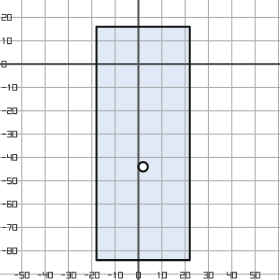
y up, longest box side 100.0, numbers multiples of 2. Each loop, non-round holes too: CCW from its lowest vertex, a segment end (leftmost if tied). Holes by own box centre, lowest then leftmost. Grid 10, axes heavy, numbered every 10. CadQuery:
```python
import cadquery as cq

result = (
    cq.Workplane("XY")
    .moveTo(-18.0, -84.0)
    .lineTo(22.0, -84.0)
    .lineTo(22.0, 16.0)
    .lineTo(-18.0, 16.0)
    .close()
    .moveTo(2.0, -44.0)
    .circle(2.0)
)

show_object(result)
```